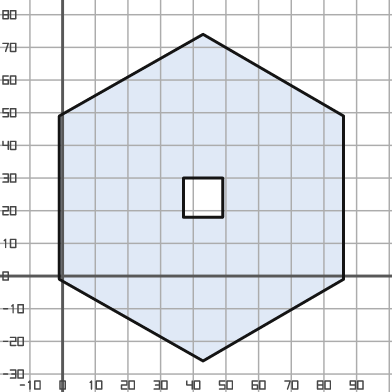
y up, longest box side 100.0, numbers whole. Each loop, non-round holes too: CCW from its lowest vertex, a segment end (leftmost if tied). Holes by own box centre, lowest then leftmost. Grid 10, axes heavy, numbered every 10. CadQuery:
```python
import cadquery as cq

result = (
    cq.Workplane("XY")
    .moveTo(43.0, -26.0)
    .lineTo(86.0, -1.0)
    .lineTo(86.0, 49.0)
    .lineTo(43.0, 74.0)
    .lineTo(-1.0, 49.0)
    .lineTo(-1.0, -1.0)
    .close()
    .moveTo(37.0, 18.0)
    .lineTo(49.0, 18.0)
    .lineTo(49.0, 30.0)
    .lineTo(37.0, 30.0)
    .close()
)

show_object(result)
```